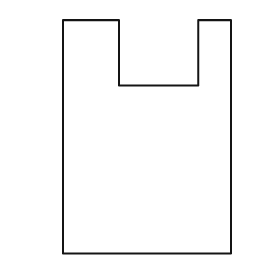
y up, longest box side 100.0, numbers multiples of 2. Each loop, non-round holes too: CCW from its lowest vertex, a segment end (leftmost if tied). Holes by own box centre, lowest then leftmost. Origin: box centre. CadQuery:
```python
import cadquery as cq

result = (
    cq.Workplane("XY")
    .moveTo(-36.0, -50.0)
    .lineTo(36.0, -50.0)
    .lineTo(36.0, 50.0)
    .lineTo(22.0, 50.0)
    .lineTo(22.0, 22.0)
    .lineTo(-12.0, 22.0)
    .lineTo(-12.0, 50.0)
    .lineTo(-36.0, 50.0)
    .close()
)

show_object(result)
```